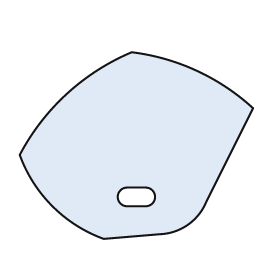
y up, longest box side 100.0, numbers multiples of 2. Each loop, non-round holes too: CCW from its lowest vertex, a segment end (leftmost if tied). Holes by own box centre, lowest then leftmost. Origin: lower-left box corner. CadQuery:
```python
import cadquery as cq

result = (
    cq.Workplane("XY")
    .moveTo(36.0, 0.0)
    .lineTo(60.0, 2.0)
    .threePointArc((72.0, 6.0), (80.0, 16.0))
    .lineTo(100.0, 56.0)
    .threePointArc((76.0, 72.0), (48.0, 80.0))
    .threePointArc((20.0, 62.0), (0.0, 36.0))
    .threePointArc((14.0, 14.0), (36.0, 0.0))
    .close()
    .moveTo(46.0, 14.0)
    .lineTo(54.0, 14.0)
    .threePointArc((58.0, 18.0), (54.0, 22.0))
    .lineTo(46.0, 22.0)
    .threePointArc((42.0, 18.0), (46.0, 14.0))
    .close()
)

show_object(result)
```